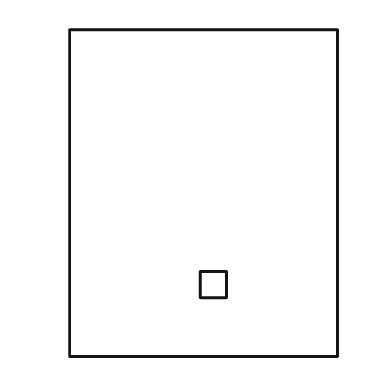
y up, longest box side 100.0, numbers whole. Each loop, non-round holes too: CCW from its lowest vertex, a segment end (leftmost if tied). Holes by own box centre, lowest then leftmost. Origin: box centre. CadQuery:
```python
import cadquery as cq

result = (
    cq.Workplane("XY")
    .moveTo(-41.0, -50.0)
    .lineTo(41.0, -50.0)
    .lineTo(41.0, 50.0)
    .lineTo(-41.0, 50.0)
    .close()
    .moveTo(-1.0, -32.0)
    .lineTo(7.0, -32.0)
    .lineTo(7.0, -24.0)
    .lineTo(-1.0, -24.0)
    .close()
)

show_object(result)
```